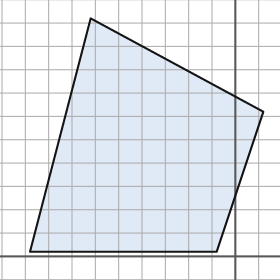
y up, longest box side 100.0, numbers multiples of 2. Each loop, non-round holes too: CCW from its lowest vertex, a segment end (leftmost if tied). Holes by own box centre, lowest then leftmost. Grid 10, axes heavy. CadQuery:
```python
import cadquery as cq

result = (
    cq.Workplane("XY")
    .moveTo(-88.0, 2.0)
    .lineTo(-8.0, 2.0)
    .lineTo(12.0, 62.0)
    .lineTo(-62.0, 102.0)
    .close()
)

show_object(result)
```